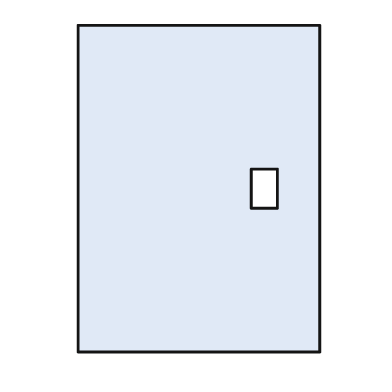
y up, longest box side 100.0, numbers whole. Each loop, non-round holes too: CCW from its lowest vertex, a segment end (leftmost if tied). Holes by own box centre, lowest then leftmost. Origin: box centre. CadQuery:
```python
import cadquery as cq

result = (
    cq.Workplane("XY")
    .moveTo(-37.0, -50.0)
    .lineTo(37.0, -50.0)
    .lineTo(37.0, 50.0)
    .lineTo(-37.0, 50.0)
    .close()
    .moveTo(16.0, -6.0)
    .lineTo(24.0, -6.0)
    .lineTo(24.0, 6.0)
    .lineTo(16.0, 6.0)
    .close()
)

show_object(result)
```